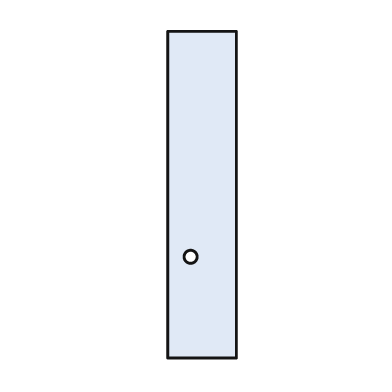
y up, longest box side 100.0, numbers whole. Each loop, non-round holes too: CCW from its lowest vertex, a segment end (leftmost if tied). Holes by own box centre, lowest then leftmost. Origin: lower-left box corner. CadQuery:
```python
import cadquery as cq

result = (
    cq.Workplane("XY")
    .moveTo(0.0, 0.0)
    .lineTo(21.0, 0.0)
    .lineTo(21.0, 100.0)
    .lineTo(0.0, 100.0)
    .close()
    .moveTo(7.0, 31.0)
    .circle(2.0)
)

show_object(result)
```